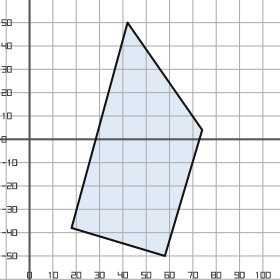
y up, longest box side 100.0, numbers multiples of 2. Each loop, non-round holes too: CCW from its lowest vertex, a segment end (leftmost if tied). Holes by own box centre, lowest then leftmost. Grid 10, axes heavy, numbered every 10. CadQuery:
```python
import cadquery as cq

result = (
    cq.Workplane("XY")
    .moveTo(58.0, -50.0)
    .lineTo(74.0, 4.0)
    .lineTo(42.0, 50.0)
    .lineTo(18.0, -38.0)
    .close()
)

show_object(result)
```